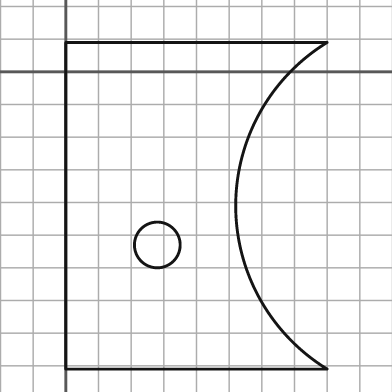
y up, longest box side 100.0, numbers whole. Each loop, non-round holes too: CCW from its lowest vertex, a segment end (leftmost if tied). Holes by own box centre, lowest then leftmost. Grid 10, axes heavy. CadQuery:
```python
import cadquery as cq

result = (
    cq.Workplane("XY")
    .moveTo(0.0, -91.0)
    .lineTo(80.0, -91.0)
    .threePointArc((52.0, -41.0), (80.0, 9.0))
    .lineTo(0.0, 9.0)
    .close()
    .moveTo(28.0, -53.0)
    .circle(7.0)
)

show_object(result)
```